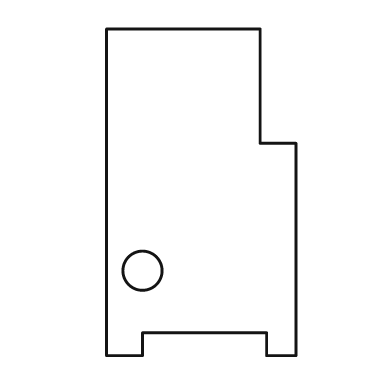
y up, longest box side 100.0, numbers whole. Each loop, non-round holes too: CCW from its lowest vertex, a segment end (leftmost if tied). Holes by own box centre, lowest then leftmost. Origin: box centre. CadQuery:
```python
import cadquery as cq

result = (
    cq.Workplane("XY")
    .moveTo(-29.0, -50.0)
    .lineTo(-18.0, -50.0)
    .lineTo(-18.0, -43.0)
    .lineTo(20.0, -43.0)
    .lineTo(20.0, -50.0)
    .lineTo(29.0, -50.0)
    .lineTo(29.0, 15.0)
    .lineTo(18.0, 15.0)
    .lineTo(18.0, 50.0)
    .lineTo(-29.0, 50.0)
    .close()
    .moveTo(-18.0, -24.0)
    .circle(6.0)
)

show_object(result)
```